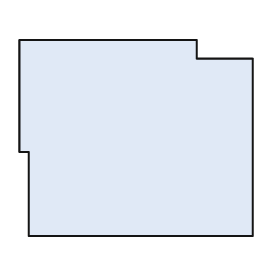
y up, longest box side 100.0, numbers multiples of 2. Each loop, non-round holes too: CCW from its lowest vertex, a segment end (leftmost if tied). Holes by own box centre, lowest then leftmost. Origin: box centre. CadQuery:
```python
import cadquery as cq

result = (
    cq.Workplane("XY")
    .moveTo(-46.0, -42.0)
    .lineTo(50.0, -42.0)
    .lineTo(50.0, 34.0)
    .lineTo(26.0, 34.0)
    .lineTo(26.0, 42.0)
    .lineTo(-50.0, 42.0)
    .lineTo(-50.0, -6.0)
    .lineTo(-46.0, -6.0)
    .close()
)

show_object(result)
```